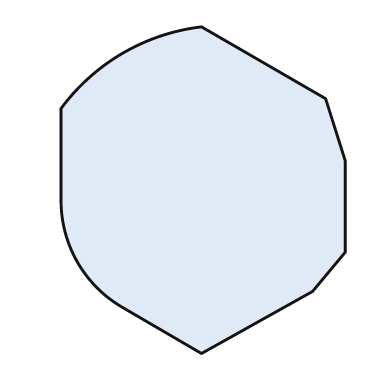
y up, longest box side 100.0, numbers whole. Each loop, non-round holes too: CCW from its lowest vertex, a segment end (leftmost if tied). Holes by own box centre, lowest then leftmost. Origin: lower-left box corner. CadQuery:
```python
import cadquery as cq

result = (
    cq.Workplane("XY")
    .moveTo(43.0, 0.0)
    .lineTo(77.0, 19.0)
    .lineTo(87.0, 31.0)
    .lineTo(87.0, 59.0)
    .lineTo(81.0, 78.0)
    .lineTo(43.0, 100.0)
    .threePointArc((19.0, 92.0), (0.0, 75.0))
    .lineTo(0.0, 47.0)
    .threePointArc((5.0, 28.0), (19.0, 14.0))
    .close()
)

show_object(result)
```